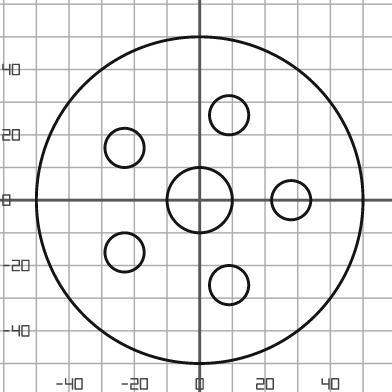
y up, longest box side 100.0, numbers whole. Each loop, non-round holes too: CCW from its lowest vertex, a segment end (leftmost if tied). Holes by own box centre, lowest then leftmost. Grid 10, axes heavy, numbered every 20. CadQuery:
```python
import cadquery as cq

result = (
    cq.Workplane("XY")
    .moveTo(0.0, 0.0)
    .circle(50.0)
    .moveTo(9.0, -26.0)
    .circle(6.0)
    .moveTo(-23.0, -16.0)
    .circle(6.0)
    .moveTo(0.0, 0.0)
    .circle(10.0)
    .moveTo(28.0, 0.0)
    .circle(6.0)
    .moveTo(-23.0, 16.0)
    .circle(6.0)
    .moveTo(9.0, 26.0)
    .circle(6.0)
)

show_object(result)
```